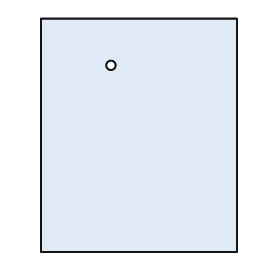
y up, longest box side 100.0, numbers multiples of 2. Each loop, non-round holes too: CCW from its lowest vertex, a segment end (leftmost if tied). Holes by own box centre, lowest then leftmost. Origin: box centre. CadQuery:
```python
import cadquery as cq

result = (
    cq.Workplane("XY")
    .moveTo(-42.0, -50.0)
    .lineTo(42.0, -50.0)
    .lineTo(42.0, 50.0)
    .lineTo(-42.0, 50.0)
    .close()
    .moveTo(-12.0, 30.0)
    .circle(2.0)
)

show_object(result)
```